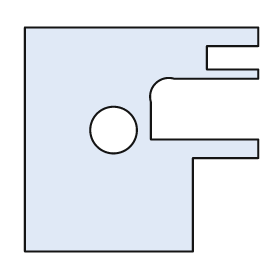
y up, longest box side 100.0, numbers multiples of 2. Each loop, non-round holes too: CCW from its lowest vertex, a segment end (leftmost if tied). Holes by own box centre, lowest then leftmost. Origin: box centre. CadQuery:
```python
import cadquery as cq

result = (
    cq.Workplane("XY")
    .moveTo(-50.0, -48.0)
    .lineTo(22.0, -48.0)
    .lineTo(22.0, -8.0)
    .lineTo(50.0, -8.0)
    .lineTo(50.0, 0.0)
    .lineTo(4.0, 0.0)
    .lineTo(4.0, 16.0)
    .threePointArc((6.0, 24.0), (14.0, 26.0))
    .lineTo(50.0, 26.0)
    .lineTo(50.0, 30.0)
    .lineTo(28.0, 30.0)
    .lineTo(28.0, 40.0)
    .lineTo(50.0, 40.0)
    .lineTo(50.0, 48.0)
    .lineTo(-50.0, 48.0)
    .close()
    .moveTo(-12.0, 4.0)
    .circle(10.0)
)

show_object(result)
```